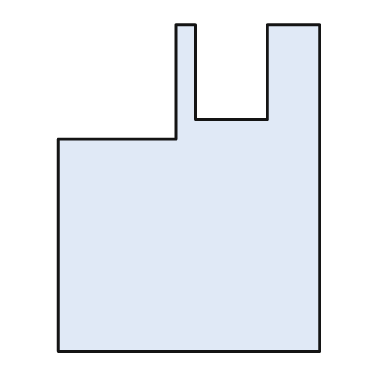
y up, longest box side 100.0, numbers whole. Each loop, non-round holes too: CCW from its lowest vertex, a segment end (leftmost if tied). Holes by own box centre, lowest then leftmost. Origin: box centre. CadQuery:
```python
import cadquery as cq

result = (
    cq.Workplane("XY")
    .moveTo(-40.0, -50.0)
    .lineTo(40.0, -50.0)
    .lineTo(40.0, 50.0)
    .lineTo(24.0, 50.0)
    .lineTo(24.0, 21.0)
    .lineTo(2.0, 21.0)
    .lineTo(2.0, 50.0)
    .lineTo(-4.0, 50.0)
    .lineTo(-4.0, 15.0)
    .lineTo(-40.0, 15.0)
    .close()
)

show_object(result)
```